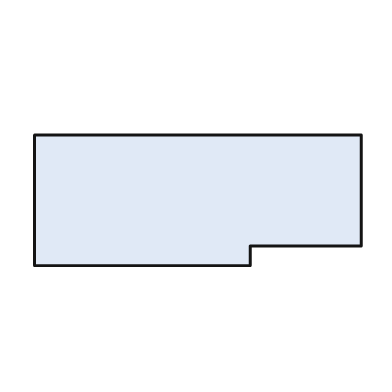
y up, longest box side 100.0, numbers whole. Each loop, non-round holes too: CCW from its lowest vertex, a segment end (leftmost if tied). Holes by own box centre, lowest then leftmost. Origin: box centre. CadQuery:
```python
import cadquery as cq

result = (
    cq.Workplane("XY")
    .moveTo(-50.0, -20.0)
    .lineTo(16.0, -20.0)
    .lineTo(16.0, -14.0)
    .lineTo(50.0, -14.0)
    .lineTo(50.0, 20.0)
    .lineTo(-50.0, 20.0)
    .close()
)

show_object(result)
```